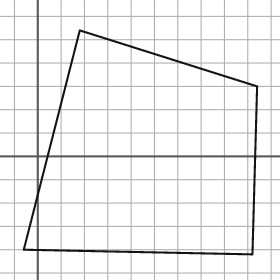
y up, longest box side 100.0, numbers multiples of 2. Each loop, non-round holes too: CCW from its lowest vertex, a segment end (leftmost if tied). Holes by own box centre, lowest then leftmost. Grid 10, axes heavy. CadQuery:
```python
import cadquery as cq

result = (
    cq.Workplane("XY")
    .moveTo(92.0, -42.0)
    .lineTo(94.0, 30.0)
    .lineTo(18.0, 54.0)
    .lineTo(-6.0, -40.0)
    .close()
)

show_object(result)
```